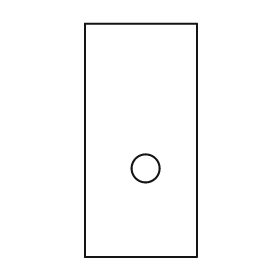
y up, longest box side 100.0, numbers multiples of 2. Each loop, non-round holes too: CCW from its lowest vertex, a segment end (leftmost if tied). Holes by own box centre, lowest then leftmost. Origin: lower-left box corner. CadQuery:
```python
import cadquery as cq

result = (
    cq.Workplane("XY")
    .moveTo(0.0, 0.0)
    .lineTo(48.0, 0.0)
    .lineTo(48.0, 100.0)
    .lineTo(0.0, 100.0)
    .close()
    .moveTo(26.0, 38.0)
    .circle(6.0)
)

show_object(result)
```